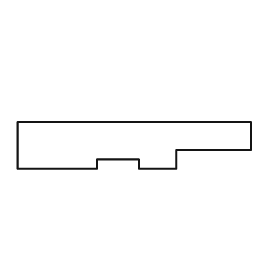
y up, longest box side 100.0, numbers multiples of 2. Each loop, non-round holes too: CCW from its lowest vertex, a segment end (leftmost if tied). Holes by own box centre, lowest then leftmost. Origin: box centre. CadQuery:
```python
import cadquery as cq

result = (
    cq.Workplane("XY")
    .moveTo(-50.0, -10.0)
    .lineTo(-16.0, -10.0)
    .lineTo(-16.0, -6.0)
    .lineTo(2.0, -6.0)
    .lineTo(2.0, -10.0)
    .lineTo(18.0, -10.0)
    .lineTo(18.0, -2.0)
    .lineTo(50.0, -2.0)
    .lineTo(50.0, 10.0)
    .lineTo(-50.0, 10.0)
    .close()
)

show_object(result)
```